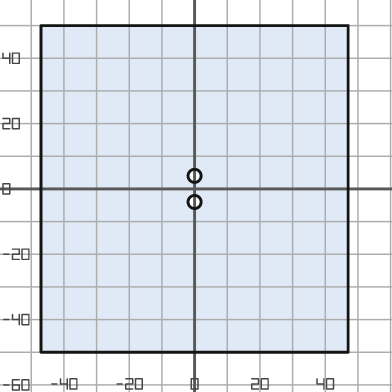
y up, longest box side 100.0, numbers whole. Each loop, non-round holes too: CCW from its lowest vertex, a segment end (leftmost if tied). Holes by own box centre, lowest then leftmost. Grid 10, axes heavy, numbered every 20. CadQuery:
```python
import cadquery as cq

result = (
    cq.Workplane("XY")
    .moveTo(-47.0, -50.0)
    .lineTo(47.0, -50.0)
    .lineTo(47.0, 50.0)
    .lineTo(-47.0, 50.0)
    .close()
    .moveTo(0.0, -4.0)
    .circle(2.0)
    .moveTo(0.0, 4.0)
    .circle(2.0)
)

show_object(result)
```